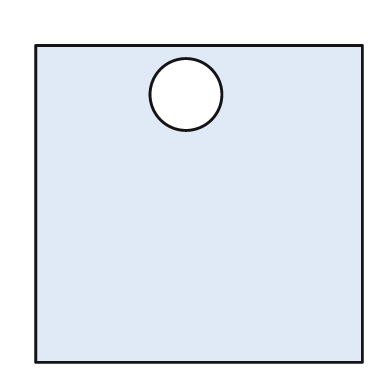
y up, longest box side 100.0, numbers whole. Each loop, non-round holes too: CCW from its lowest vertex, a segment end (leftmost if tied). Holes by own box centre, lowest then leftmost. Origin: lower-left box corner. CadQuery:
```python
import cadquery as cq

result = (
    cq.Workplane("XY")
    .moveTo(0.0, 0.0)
    .lineTo(100.0, 0.0)
    .lineTo(100.0, 97.0)
    .lineTo(0.0, 97.0)
    .close()
    .moveTo(46.0, 82.0)
    .circle(11.0)
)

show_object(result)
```